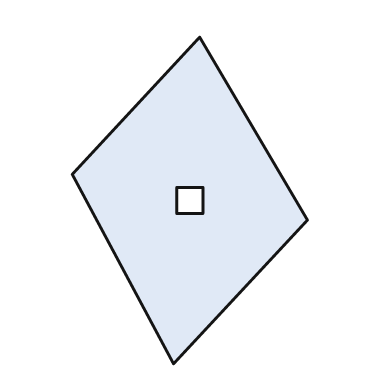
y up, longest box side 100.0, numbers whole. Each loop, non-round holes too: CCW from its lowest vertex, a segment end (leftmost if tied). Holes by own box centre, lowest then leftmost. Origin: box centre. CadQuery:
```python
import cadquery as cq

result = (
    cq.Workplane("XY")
    .moveTo(-5.0, -50.0)
    .lineTo(36.0, -6.0)
    .lineTo(3.0, 50.0)
    .lineTo(-36.0, 8.0)
    .close()
    .moveTo(-4.0, -4.0)
    .lineTo(4.0, -4.0)
    .lineTo(4.0, 4.0)
    .lineTo(-4.0, 4.0)
    .close()
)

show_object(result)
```